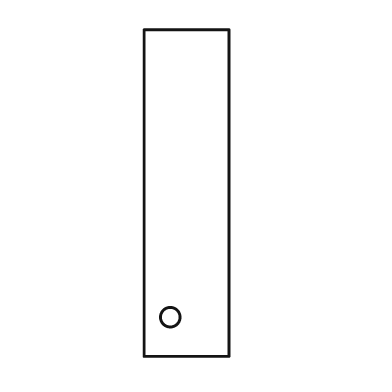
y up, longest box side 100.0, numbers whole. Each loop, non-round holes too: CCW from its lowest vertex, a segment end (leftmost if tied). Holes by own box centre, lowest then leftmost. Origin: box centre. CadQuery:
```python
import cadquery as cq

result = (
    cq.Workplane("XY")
    .moveTo(-13.0, -50.0)
    .lineTo(13.0, -50.0)
    .lineTo(13.0, 50.0)
    .lineTo(-13.0, 50.0)
    .close()
    .moveTo(-5.0, -38.0)
    .circle(3.0)
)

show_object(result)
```